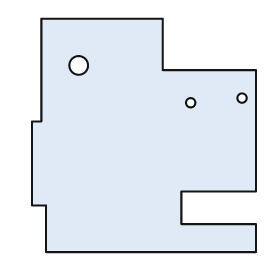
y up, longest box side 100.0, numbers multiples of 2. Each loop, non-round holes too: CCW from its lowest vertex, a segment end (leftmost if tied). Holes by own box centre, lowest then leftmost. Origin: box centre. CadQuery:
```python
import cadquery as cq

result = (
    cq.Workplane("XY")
    .moveTo(-42.0, -50.0)
    .lineTo(48.0, -50.0)
    .lineTo(48.0, -38.0)
    .lineTo(16.0, -38.0)
    .lineTo(16.0, -24.0)
    .lineTo(48.0, -24.0)
    .lineTo(48.0, 28.0)
    .lineTo(8.0, 28.0)
    .lineTo(8.0, 50.0)
    .lineTo(-44.0, 50.0)
    .lineTo(-44.0, 6.0)
    .lineTo(-48.0, 6.0)
    .lineTo(-48.0, -30.0)
    .lineTo(-42.0, -30.0)
    .close()
    .moveTo(20.0, 14.0)
    .circle(2.0)
    .moveTo(42.0, 16.0)
    .circle(2.0)
    .moveTo(-28.0, 30.0)
    .circle(4.0)
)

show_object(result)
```